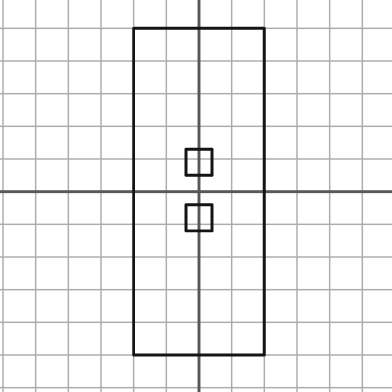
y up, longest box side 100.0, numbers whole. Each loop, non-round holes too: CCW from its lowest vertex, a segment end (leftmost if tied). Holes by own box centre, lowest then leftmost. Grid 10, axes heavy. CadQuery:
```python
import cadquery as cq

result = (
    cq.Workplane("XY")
    .moveTo(-20.0, -50.0)
    .lineTo(20.0, -50.0)
    .lineTo(20.0, 50.0)
    .lineTo(-20.0, 50.0)
    .close()
    .moveTo(-4.0, -12.0)
    .lineTo(4.0, -12.0)
    .lineTo(4.0, -4.0)
    .lineTo(-4.0, -4.0)
    .close()
    .moveTo(-4.0, 5.0)
    .lineTo(4.0, 5.0)
    .lineTo(4.0, 13.0)
    .lineTo(-4.0, 13.0)
    .close()
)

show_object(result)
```